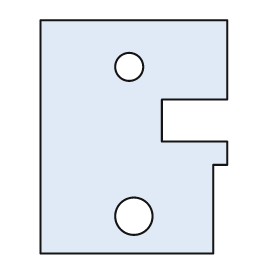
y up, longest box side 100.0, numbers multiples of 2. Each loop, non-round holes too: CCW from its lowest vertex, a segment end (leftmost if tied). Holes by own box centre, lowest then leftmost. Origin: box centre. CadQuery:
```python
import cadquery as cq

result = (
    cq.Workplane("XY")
    .moveTo(-40.0, -50.0)
    .lineTo(34.0, -50.0)
    .lineTo(34.0, -12.0)
    .lineTo(40.0, -12.0)
    .lineTo(40.0, -2.0)
    .lineTo(12.0, -2.0)
    .lineTo(12.0, 16.0)
    .lineTo(40.0, 16.0)
    .lineTo(40.0, 50.0)
    .lineTo(-40.0, 50.0)
    .close()
    .moveTo(0.0, -34.0)
    .circle(8.0)
    .moveTo(-2.0, 30.0)
    .circle(6.0)
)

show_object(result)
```